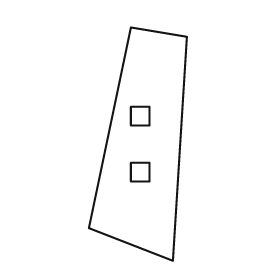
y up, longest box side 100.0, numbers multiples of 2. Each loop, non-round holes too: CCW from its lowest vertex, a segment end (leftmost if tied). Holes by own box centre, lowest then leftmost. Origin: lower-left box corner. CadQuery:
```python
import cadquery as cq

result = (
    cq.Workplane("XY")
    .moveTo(36.0, 0.0)
    .lineTo(42.0, 96.0)
    .lineTo(18.0, 100.0)
    .lineTo(0.0, 14.0)
    .close()
    .moveTo(18.0, 34.0)
    .lineTo(26.0, 34.0)
    .lineTo(26.0, 42.0)
    .lineTo(18.0, 42.0)
    .close()
    .moveTo(18.0, 58.0)
    .lineTo(26.0, 58.0)
    .lineTo(26.0, 66.0)
    .lineTo(18.0, 66.0)
    .close()
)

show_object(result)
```